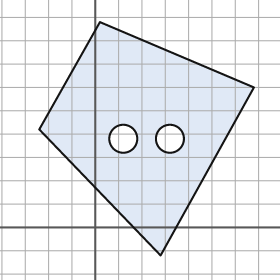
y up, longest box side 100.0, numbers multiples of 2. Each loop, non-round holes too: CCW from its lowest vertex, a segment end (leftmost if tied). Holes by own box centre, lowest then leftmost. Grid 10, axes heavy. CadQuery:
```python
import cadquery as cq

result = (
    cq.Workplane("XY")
    .moveTo(28.0, -12.0)
    .lineTo(68.0, 60.0)
    .lineTo(2.0, 88.0)
    .lineTo(-24.0, 42.0)
    .close()
    .moveTo(12.0, 38.0)
    .circle(6.0)
    .moveTo(32.0, 38.0)
    .circle(6.0)
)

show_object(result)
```